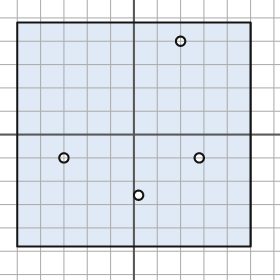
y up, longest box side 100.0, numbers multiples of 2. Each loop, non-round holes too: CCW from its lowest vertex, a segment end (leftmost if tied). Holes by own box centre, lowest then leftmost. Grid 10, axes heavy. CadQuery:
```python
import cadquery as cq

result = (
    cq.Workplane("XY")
    .moveTo(-50.0, -48.0)
    .lineTo(50.0, -48.0)
    .lineTo(50.0, 48.0)
    .lineTo(-50.0, 48.0)
    .close()
    .moveTo(2.0, -26.0)
    .circle(2.0)
    .moveTo(-30.0, -10.0)
    .circle(2.0)
    .moveTo(28.0, -10.0)
    .circle(2.0)
    .moveTo(20.0, 40.0)
    .circle(2.0)
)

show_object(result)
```